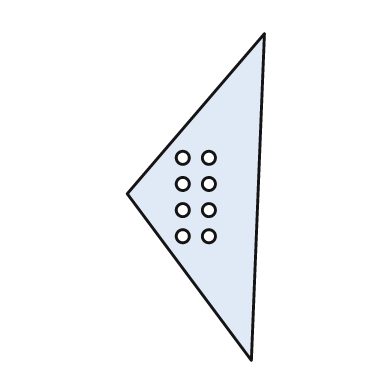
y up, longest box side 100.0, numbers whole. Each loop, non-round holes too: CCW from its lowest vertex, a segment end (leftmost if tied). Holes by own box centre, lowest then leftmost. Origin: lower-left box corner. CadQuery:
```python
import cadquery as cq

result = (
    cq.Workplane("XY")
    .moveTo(38.0, 0.0)
    .lineTo(42.0, 100.0)
    .lineTo(0.0, 51.0)
    .close()
    .moveTo(17.0, 38.0)
    .circle(2.0)
    .moveTo(25.0, 38.0)
    .circle(2.0)
    .moveTo(17.0, 46.0)
    .circle(2.0)
    .moveTo(25.0, 46.0)
    .circle(2.0)
    .moveTo(17.0, 54.0)
    .circle(2.0)
    .moveTo(25.0, 54.0)
    .circle(2.0)
    .moveTo(17.0, 62.0)
    .circle(2.0)
    .moveTo(25.0, 62.0)
    .circle(2.0)
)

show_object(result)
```